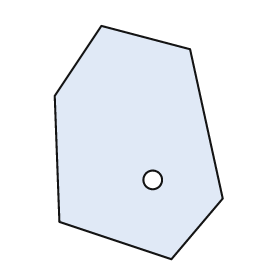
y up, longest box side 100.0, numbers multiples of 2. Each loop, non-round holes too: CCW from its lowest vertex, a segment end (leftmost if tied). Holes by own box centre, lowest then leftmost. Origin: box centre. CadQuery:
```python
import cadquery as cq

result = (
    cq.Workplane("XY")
    .moveTo(14.0, -50.0)
    .lineTo(36.0, -24.0)
    .lineTo(22.0, 40.0)
    .lineTo(-16.0, 50.0)
    .lineTo(-36.0, 20.0)
    .lineTo(-34.0, -34.0)
    .close()
    .moveTo(6.0, -16.0)
    .circle(4.0)
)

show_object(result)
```